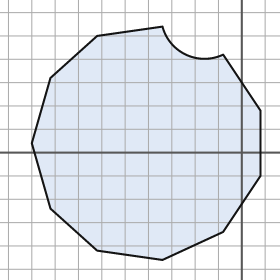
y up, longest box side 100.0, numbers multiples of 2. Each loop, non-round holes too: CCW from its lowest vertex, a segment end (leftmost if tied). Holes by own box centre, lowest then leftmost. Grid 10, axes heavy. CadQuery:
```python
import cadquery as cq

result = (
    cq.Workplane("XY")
    .moveTo(-34.0, -46.0)
    .lineTo(-8.0, -34.0)
    .lineTo(8.0, -10.0)
    .lineTo(8.0, 18.0)
    .lineTo(-8.0, 42.0)
    .threePointArc((-24.0, 42.0), (-34.0, 54.0))
    .lineTo(-62.0, 50.0)
    .lineTo(-82.0, 32.0)
    .lineTo(-90.0, 4.0)
    .lineTo(-82.0, -24.0)
    .lineTo(-62.0, -42.0)
    .close()
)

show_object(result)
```